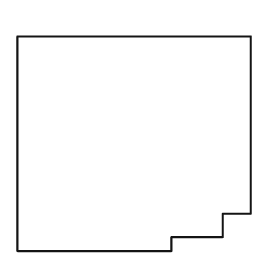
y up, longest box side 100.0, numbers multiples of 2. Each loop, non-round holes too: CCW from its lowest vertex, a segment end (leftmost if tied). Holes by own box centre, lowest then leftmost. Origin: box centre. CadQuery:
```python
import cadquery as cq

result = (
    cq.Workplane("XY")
    .moveTo(-50.0, -46.0)
    .lineTo(16.0, -46.0)
    .lineTo(16.0, -40.0)
    .lineTo(38.0, -40.0)
    .lineTo(38.0, -30.0)
    .lineTo(50.0, -30.0)
    .lineTo(50.0, 46.0)
    .lineTo(-50.0, 46.0)
    .close()
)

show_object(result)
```